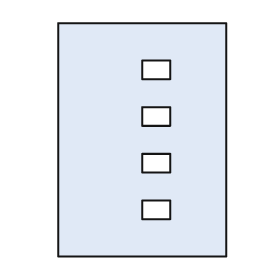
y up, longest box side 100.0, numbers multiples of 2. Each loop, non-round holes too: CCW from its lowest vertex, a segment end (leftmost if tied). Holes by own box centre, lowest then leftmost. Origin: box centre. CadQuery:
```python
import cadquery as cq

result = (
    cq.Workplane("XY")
    .moveTo(-36.0, -50.0)
    .lineTo(36.0, -50.0)
    .lineTo(36.0, 50.0)
    .lineTo(-36.0, 50.0)
    .close()
    .moveTo(0.0, -34.0)
    .lineTo(12.0, -34.0)
    .lineTo(12.0, -26.0)
    .lineTo(0.0, -26.0)
    .close()
    .moveTo(0.0, -14.0)
    .lineTo(12.0, -14.0)
    .lineTo(12.0, -6.0)
    .lineTo(0.0, -6.0)
    .close()
    .moveTo(0.0, 6.0)
    .lineTo(12.0, 6.0)
    .lineTo(12.0, 14.0)
    .lineTo(0.0, 14.0)
    .close()
    .moveTo(0.0, 26.0)
    .lineTo(12.0, 26.0)
    .lineTo(12.0, 34.0)
    .lineTo(0.0, 34.0)
    .close()
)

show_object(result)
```